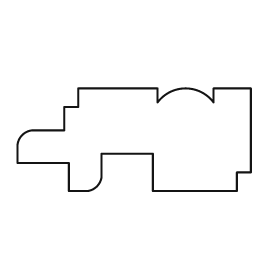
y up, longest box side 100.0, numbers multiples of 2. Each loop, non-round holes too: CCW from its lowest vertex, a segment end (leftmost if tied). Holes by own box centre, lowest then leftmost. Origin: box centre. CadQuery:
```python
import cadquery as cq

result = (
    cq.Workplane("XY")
    .moveTo(-28.0, -22.0)
    .lineTo(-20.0, -22.0)
    .threePointArc((-16.0, -20.0), (-14.0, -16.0))
    .lineTo(-14.0, -6.0)
    .lineTo(8.0, -6.0)
    .lineTo(8.0, -22.0)
    .lineTo(44.0, -22.0)
    .lineTo(44.0, -14.0)
    .lineTo(50.0, -14.0)
    .lineTo(50.0, 22.0)
    .lineTo(34.0, 22.0)
    .lineTo(34.0, 16.0)
    .threePointArc((22.0, 22.0), (10.0, 16.0))
    .lineTo(10.0, 22.0)
    .lineTo(-24.0, 22.0)
    .lineTo(-24.0, 14.0)
    .lineTo(-30.0, 14.0)
    .lineTo(-30.0, 4.0)
    .lineTo(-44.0, 4.0)
    .threePointArc((-48.0, 2.0), (-50.0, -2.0))
    .lineTo(-50.0, -10.0)
    .lineTo(-28.0, -10.0)
    .close()
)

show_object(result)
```